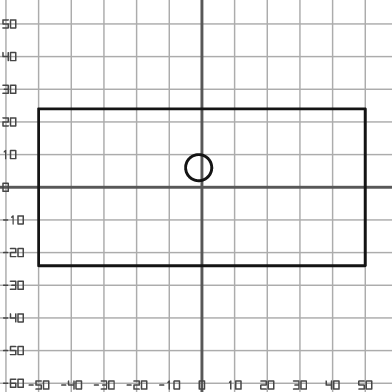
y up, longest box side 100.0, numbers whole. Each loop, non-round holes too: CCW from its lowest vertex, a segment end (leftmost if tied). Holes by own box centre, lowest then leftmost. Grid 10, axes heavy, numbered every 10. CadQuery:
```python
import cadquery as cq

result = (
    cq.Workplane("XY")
    .moveTo(-50.0, -24.0)
    .lineTo(50.0, -24.0)
    .lineTo(50.0, 24.0)
    .lineTo(-50.0, 24.0)
    .close()
    .moveTo(-1.0, 6.0)
    .circle(4.0)
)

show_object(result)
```